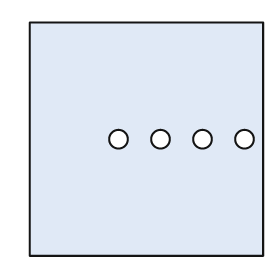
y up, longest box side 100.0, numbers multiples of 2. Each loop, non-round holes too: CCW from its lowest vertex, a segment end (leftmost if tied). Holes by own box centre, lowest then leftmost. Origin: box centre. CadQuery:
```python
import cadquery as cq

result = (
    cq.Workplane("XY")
    .moveTo(-50.0, -50.0)
    .lineTo(50.0, -50.0)
    .lineTo(50.0, 50.0)
    .lineTo(-50.0, 50.0)
    .close()
    .moveTo(-12.0, 0.0)
    .circle(4.0)
    .moveTo(6.0, 0.0)
    .circle(4.0)
    .moveTo(24.0, 0.0)
    .circle(4.0)
    .moveTo(42.0, 0.0)
    .circle(4.0)
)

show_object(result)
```